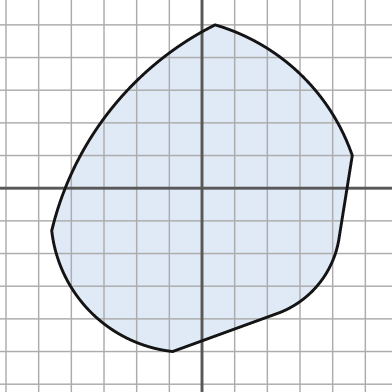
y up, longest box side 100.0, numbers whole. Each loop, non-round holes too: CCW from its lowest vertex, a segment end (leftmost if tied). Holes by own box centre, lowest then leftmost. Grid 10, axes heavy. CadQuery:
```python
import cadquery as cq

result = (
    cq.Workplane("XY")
    .moveTo(-9.0, -50.0)
    .lineTo(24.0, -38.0)
    .threePointArc((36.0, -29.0), (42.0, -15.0))
    .lineTo(46.0, 10.0)
    .threePointArc((30.0, 35.0), (4.0, 50.0))
    .threePointArc((-28.0, 24.0), (-46.0, -13.0))
    .threePointArc((-34.0, -38.0), (-9.0, -50.0))
    .close()
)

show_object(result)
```